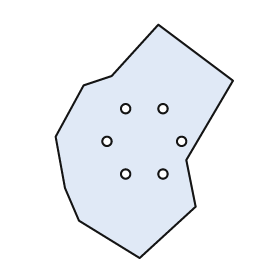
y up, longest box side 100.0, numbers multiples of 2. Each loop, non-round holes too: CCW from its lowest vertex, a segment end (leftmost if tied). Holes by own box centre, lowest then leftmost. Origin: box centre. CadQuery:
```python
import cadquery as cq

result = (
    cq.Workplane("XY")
    .moveTo(-2.0, -50.0)
    .lineTo(22.0, -28.0)
    .lineTo(18.0, -8.0)
    .lineTo(38.0, 26.0)
    .lineTo(6.0, 50.0)
    .lineTo(-14.0, 28.0)
    .lineTo(-26.0, 24.0)
    .lineTo(-38.0, 2.0)
    .lineTo(-34.0, -20.0)
    .lineTo(-28.0, -34.0)
    .close()
    .moveTo(-8.0, -14.0)
    .circle(2.0)
    .moveTo(8.0, -14.0)
    .circle(2.0)
    .moveTo(-16.0, 0.0)
    .circle(2.0)
    .moveTo(16.0, 0.0)
    .circle(2.0)
    .moveTo(-8.0, 14.0)
    .circle(2.0)
    .moveTo(8.0, 14.0)
    .circle(2.0)
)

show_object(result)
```